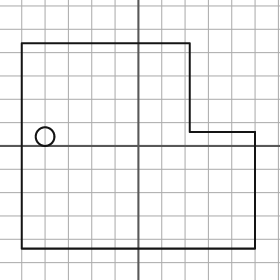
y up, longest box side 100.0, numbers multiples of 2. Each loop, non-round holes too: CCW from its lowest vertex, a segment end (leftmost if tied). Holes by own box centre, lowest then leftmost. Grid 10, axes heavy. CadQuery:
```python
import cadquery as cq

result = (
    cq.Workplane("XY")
    .moveTo(-50.0, -44.0)
    .lineTo(50.0, -44.0)
    .lineTo(50.0, 6.0)
    .lineTo(22.0, 6.0)
    .lineTo(22.0, 44.0)
    .lineTo(-50.0, 44.0)
    .close()
    .moveTo(-40.0, 4.0)
    .circle(4.0)
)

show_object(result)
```